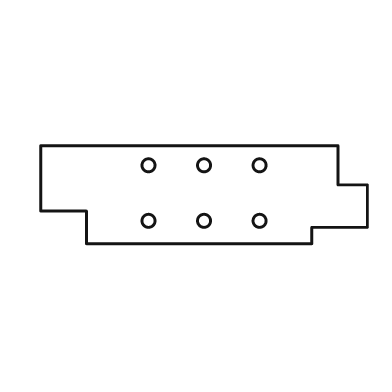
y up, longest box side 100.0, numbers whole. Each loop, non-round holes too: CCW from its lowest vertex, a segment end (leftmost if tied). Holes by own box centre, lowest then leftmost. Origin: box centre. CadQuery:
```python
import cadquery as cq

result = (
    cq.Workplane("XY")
    .moveTo(-36.0, -15.0)
    .lineTo(33.0, -15.0)
    .lineTo(33.0, -10.0)
    .lineTo(50.0, -10.0)
    .lineTo(50.0, 3.0)
    .lineTo(41.0, 3.0)
    .lineTo(41.0, 15.0)
    .lineTo(-50.0, 15.0)
    .lineTo(-50.0, -5.0)
    .lineTo(-36.0, -5.0)
    .close()
    .moveTo(-17.0, -8.0)
    .circle(2.0)
    .moveTo(0.0, -8.0)
    .circle(2.0)
    .moveTo(17.0, -8.0)
    .circle(2.0)
    .moveTo(-17.0, 9.0)
    .circle(2.0)
    .moveTo(0.0, 9.0)
    .circle(2.0)
    .moveTo(17.0, 9.0)
    .circle(2.0)
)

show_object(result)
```